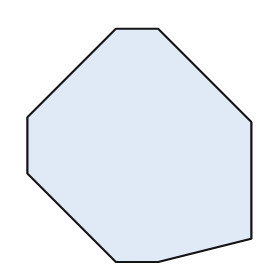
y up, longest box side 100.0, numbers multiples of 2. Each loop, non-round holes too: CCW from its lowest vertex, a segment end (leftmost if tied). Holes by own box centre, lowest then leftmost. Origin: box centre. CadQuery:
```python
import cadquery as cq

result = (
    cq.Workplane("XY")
    .moveTo(-10.0, -50.0)
    .lineTo(8.0, -50.0)
    .lineTo(48.0, -40.0)
    .lineTo(48.0, 10.0)
    .lineTo(8.0, 50.0)
    .lineTo(-10.0, 50.0)
    .lineTo(-48.0, 12.0)
    .lineTo(-48.0, -12.0)
    .close()
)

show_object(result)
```